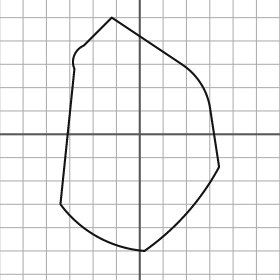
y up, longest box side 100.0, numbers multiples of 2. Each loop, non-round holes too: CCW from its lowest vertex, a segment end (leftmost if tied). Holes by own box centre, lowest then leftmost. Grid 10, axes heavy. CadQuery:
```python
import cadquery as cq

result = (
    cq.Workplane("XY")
    .moveTo(2.0, -50.0)
    .threePointArc((20.0, -34.0), (34.0, -14.0))
    .lineTo(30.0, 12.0)
    .threePointArc((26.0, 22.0), (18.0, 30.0))
    .lineTo(-12.0, 50.0)
    .lineTo(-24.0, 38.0)
    .threePointArc((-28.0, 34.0), (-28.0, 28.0))
    .lineTo(-34.0, -30.0)
    .threePointArc((-18.0, -44.0), (2.0, -50.0))
    .close()
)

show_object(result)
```